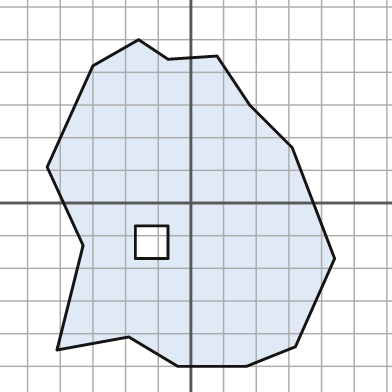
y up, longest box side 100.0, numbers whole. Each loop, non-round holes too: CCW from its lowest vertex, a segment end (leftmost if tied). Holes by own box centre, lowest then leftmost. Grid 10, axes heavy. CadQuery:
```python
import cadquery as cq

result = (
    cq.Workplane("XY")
    .moveTo(-4.0, -50.0)
    .lineTo(17.0, -50.0)
    .lineTo(32.0, -44.0)
    .lineTo(44.0, -17.0)
    .lineTo(31.0, 17.0)
    .lineTo(18.0, 30.0)
    .lineTo(8.0, 45.0)
    .lineTo(-7.0, 44.0)
    .lineTo(-16.0, 50.0)
    .lineTo(-30.0, 42.0)
    .lineTo(-44.0, 11.0)
    .lineTo(-33.0, -13.0)
    .lineTo(-41.0, -45.0)
    .lineTo(-19.0, -41.0)
    .close()
    .moveTo(-17.0, -17.0)
    .lineTo(-7.0, -17.0)
    .lineTo(-7.0, -7.0)
    .lineTo(-17.0, -7.0)
    .close()
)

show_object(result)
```